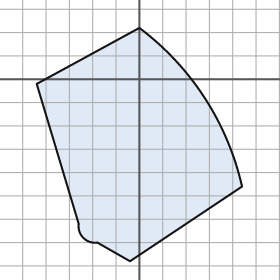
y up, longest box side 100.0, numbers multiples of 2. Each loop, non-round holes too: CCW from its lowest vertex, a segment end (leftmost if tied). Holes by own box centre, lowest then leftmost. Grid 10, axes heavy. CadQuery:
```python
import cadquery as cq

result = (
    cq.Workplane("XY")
    .moveTo(-4.0, -78.0)
    .lineTo(44.0, -46.0)
    .threePointArc((28.0, -8.0), (0.0, 22.0))
    .lineTo(-44.0, -2.0)
    .lineTo(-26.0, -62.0)
    .threePointArc((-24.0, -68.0), (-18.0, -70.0))
    .close()
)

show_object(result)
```